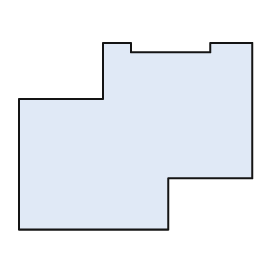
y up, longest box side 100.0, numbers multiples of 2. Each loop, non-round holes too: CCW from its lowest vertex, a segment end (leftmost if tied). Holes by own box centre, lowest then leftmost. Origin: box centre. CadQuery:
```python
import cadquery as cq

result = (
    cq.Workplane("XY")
    .moveTo(-50.0, -40.0)
    .lineTo(14.0, -40.0)
    .lineTo(14.0, -18.0)
    .lineTo(50.0, -18.0)
    .lineTo(50.0, 40.0)
    .lineTo(32.0, 40.0)
    .lineTo(32.0, 36.0)
    .lineTo(-2.0, 36.0)
    .lineTo(-2.0, 40.0)
    .lineTo(-14.0, 40.0)
    .lineTo(-14.0, 16.0)
    .lineTo(-50.0, 16.0)
    .close()
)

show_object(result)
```